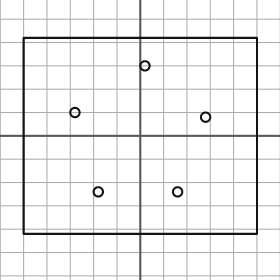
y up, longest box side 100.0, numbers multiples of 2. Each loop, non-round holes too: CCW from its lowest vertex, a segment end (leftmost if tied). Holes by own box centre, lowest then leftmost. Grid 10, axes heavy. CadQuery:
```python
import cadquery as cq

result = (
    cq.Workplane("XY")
    .moveTo(-50.0, -42.0)
    .lineTo(50.0, -42.0)
    .lineTo(50.0, 42.0)
    .lineTo(-50.0, 42.0)
    .close()
    .moveTo(-18.0, -24.0)
    .circle(2.0)
    .moveTo(16.0, -24.0)
    .circle(2.0)
    .moveTo(28.0, 8.0)
    .circle(2.0)
    .moveTo(-28.0, 10.0)
    .circle(2.0)
    .moveTo(2.0, 30.0)
    .circle(2.0)
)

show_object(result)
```